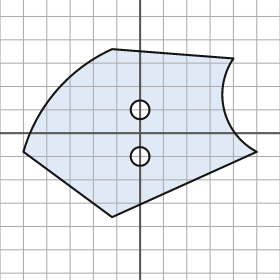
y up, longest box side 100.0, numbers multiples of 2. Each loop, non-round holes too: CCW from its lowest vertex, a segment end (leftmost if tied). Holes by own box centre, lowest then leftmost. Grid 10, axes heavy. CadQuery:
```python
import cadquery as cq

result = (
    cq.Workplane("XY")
    .moveTo(-12.0, -36.0)
    .lineTo(50.0, -8.0)
    .threePointArc((36.0, 10.0), (40.0, 32.0))
    .lineTo(-12.0, 36.0)
    .threePointArc((-36.0, 18.0), (-50.0, -8.0))
    .close()
    .moveTo(0.0, -10.0)
    .circle(4.0)
    .moveTo(0.0, 10.0)
    .circle(4.0)
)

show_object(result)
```